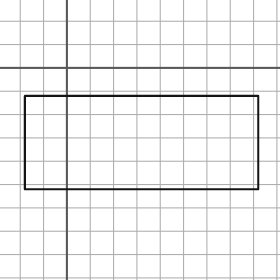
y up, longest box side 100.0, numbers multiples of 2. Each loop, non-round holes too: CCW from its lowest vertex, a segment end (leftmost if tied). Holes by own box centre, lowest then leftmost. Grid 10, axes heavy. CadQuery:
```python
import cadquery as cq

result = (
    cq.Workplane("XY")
    .moveTo(-18.0, -52.0)
    .lineTo(82.0, -52.0)
    .lineTo(82.0, -12.0)
    .lineTo(-18.0, -12.0)
    .close()
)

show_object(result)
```